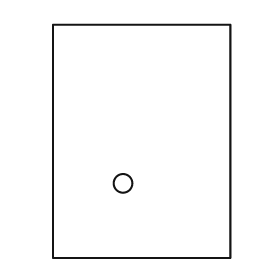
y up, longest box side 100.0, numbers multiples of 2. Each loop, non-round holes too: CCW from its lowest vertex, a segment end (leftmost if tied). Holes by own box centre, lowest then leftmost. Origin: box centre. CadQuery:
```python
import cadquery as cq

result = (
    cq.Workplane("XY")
    .moveTo(-38.0, -50.0)
    .lineTo(38.0, -50.0)
    .lineTo(38.0, 50.0)
    .lineTo(-38.0, 50.0)
    .close()
    .moveTo(-8.0, -18.0)
    .circle(4.0)
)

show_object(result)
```